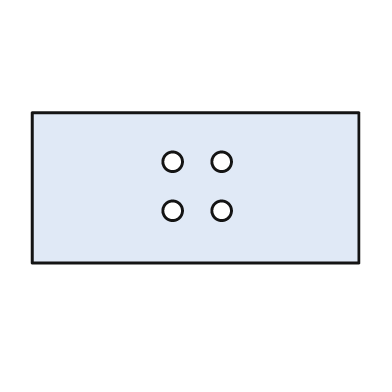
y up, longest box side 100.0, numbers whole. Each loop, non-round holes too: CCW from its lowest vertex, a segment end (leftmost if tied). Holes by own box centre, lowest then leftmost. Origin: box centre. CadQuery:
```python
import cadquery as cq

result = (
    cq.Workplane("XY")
    .moveTo(-50.0, -23.0)
    .lineTo(50.0, -23.0)
    .lineTo(50.0, 23.0)
    .lineTo(-50.0, 23.0)
    .close()
    .moveTo(-7.0, -7.0)
    .circle(3.0)
    .moveTo(8.0, -7.0)
    .circle(3.0)
    .moveTo(-7.0, 8.0)
    .circle(3.0)
    .moveTo(8.0, 8.0)
    .circle(3.0)
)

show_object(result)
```